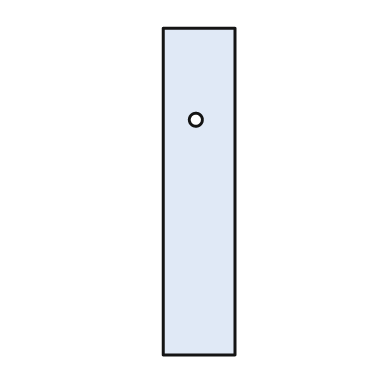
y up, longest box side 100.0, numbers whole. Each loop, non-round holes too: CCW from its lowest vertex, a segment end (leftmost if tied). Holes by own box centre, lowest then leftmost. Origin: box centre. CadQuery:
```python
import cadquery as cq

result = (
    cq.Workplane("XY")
    .moveTo(-11.0, -50.0)
    .lineTo(11.0, -50.0)
    .lineTo(11.0, 50.0)
    .lineTo(-11.0, 50.0)
    .close()
    .moveTo(-1.0, 22.0)
    .circle(2.0)
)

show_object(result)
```